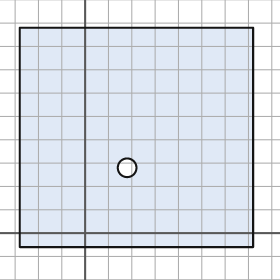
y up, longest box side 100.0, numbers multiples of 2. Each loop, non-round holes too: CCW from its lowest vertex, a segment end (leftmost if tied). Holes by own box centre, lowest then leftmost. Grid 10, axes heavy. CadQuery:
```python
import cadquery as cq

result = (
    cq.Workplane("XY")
    .moveTo(-28.0, -6.0)
    .lineTo(72.0, -6.0)
    .lineTo(72.0, 88.0)
    .lineTo(-28.0, 88.0)
    .close()
    .moveTo(18.0, 28.0)
    .circle(4.0)
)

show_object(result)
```